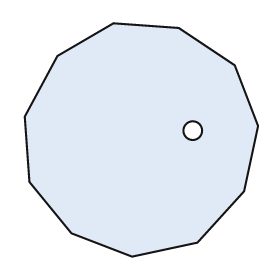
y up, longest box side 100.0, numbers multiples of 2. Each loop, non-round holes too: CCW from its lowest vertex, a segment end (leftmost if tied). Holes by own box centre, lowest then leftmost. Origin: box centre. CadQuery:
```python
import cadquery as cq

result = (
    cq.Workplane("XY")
    .moveTo(-4.0, -50.0)
    .lineTo(24.0, -44.0)
    .lineTo(44.0, -22.0)
    .lineTo(50.0, 6.0)
    .lineTo(40.0, 32.0)
    .lineTo(16.0, 48.0)
    .lineTo(-12.0, 50.0)
    .lineTo(-36.0, 36.0)
    .lineTo(-50.0, 10.0)
    .lineTo(-48.0, -18.0)
    .lineTo(-30.0, -40.0)
    .close()
    .moveTo(22.0, 4.0)
    .circle(4.0)
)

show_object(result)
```